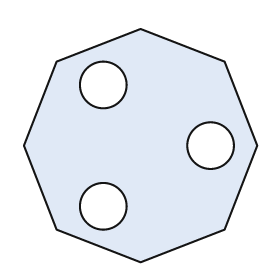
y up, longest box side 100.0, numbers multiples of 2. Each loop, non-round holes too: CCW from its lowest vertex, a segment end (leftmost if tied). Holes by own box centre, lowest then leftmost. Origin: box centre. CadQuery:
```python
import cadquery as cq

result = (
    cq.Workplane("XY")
    .moveTo(0.0, -50.0)
    .lineTo(36.0, -36.0)
    .lineTo(50.0, 0.0)
    .lineTo(36.0, 36.0)
    .lineTo(0.0, 50.0)
    .lineTo(-36.0, 36.0)
    .lineTo(-50.0, 0.0)
    .lineTo(-36.0, -36.0)
    .close()
    .moveTo(-16.0, -26.0)
    .circle(10.0)
    .moveTo(30.0, 0.0)
    .circle(10.0)
    .moveTo(-16.0, 26.0)
    .circle(10.0)
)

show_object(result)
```